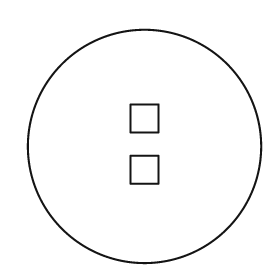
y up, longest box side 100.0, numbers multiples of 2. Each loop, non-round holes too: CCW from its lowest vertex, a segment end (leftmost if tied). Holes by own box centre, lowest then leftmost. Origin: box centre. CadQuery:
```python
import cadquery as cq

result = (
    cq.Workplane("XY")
    .moveTo(0.0, 0.0)
    .circle(50.0)
    .moveTo(-6.0, -16.0)
    .lineTo(6.0, -16.0)
    .lineTo(6.0, -4.0)
    .lineTo(-6.0, -4.0)
    .close()
    .moveTo(-6.0, 6.0)
    .lineTo(6.0, 6.0)
    .lineTo(6.0, 18.0)
    .lineTo(-6.0, 18.0)
    .close()
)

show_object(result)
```